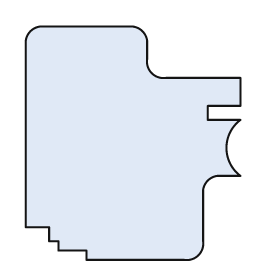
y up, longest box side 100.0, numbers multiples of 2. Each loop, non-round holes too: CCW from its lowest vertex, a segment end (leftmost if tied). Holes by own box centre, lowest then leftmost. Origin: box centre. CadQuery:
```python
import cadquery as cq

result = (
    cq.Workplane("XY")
    .moveTo(-20.0, -50.0)
    .lineTo(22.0, -50.0)
    .threePointArc((28.0, -48.0), (30.0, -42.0))
    .lineTo(30.0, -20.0)
    .threePointArc((32.0, -16.0), (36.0, -14.0))
    .lineTo(46.0, -14.0)
    .threePointArc((40.0, -2.0), (46.0, 10.0))
    .lineTo(32.0, 10.0)
    .lineTo(32.0, 16.0)
    .lineTo(46.0, 16.0)
    .lineTo(46.0, 28.0)
    .lineTo(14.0, 28.0)
    .threePointArc((8.0, 30.0), (6.0, 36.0))
    .lineTo(6.0, 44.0)
    .threePointArc((4.0, 48.0), (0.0, 50.0))
    .lineTo(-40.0, 50.0)
    .threePointArc((-44.0, 48.0), (-46.0, 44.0))
    .lineTo(-46.0, -36.0)
    .lineTo(-36.0, -36.0)
    .lineTo(-36.0, -42.0)
    .lineTo(-32.0, -42.0)
    .lineTo(-32.0, -46.0)
    .lineTo(-20.0, -46.0)
    .close()
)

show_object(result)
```